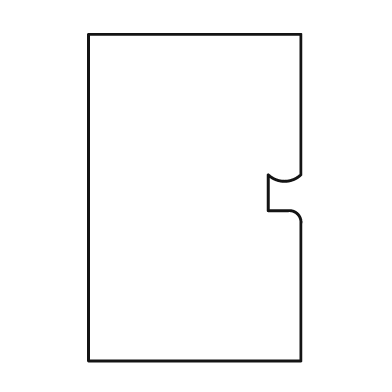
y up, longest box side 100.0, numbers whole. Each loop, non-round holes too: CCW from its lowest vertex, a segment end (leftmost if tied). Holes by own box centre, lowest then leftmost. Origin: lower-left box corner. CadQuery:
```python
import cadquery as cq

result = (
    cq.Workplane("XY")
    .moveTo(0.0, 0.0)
    .lineTo(65.0, 0.0)
    .lineTo(65.0, 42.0)
    .threePointArc((64.0, 45.0), (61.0, 46.0))
    .lineTo(55.0, 46.0)
    .lineTo(55.0, 57.0)
    .threePointArc((60.0, 55.0), (65.0, 57.0))
    .lineTo(65.0, 100.0)
    .lineTo(0.0, 100.0)
    .close()
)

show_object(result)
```